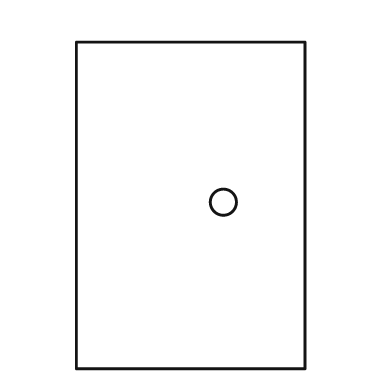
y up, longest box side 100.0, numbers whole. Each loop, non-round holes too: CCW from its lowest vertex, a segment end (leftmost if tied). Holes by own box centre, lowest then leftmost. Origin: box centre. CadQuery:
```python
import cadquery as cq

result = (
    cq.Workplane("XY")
    .moveTo(-35.0, -50.0)
    .lineTo(35.0, -50.0)
    .lineTo(35.0, 50.0)
    .lineTo(-35.0, 50.0)
    .close()
    .moveTo(10.0, 1.0)
    .circle(4.0)
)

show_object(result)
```